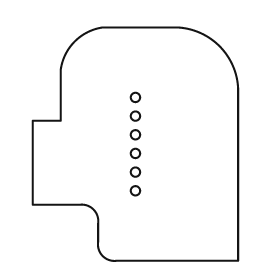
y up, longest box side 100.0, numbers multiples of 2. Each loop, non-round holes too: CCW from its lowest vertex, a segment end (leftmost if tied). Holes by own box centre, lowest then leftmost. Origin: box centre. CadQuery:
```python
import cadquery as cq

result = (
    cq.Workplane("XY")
    .moveTo(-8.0, -50.0)
    .lineTo(44.0, -50.0)
    .lineTo(44.0, 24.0)
    .threePointArc((36.0, 42.0), (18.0, 50.0))
    .lineTo(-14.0, 50.0)
    .threePointArc((-26.0, 44.0), (-32.0, 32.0))
    .lineTo(-32.0, 10.0)
    .lineTo(-44.0, 10.0)
    .lineTo(-44.0, -26.0)
    .lineTo(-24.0, -26.0)
    .threePointArc((-18.0, -28.0), (-16.0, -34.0))
    .lineTo(-16.0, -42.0)
    .threePointArc((-14.0, -48.0), (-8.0, -50.0))
    .close()
    .moveTo(0.0, -20.0)
    .circle(2.0)
    .moveTo(0.0, -12.0)
    .circle(2.0)
    .moveTo(0.0, -4.0)
    .circle(2.0)
    .moveTo(0.0, 4.0)
    .circle(2.0)
    .moveTo(0.0, 12.0)
    .circle(2.0)
    .moveTo(0.0, 20.0)
    .circle(2.0)
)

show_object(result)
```